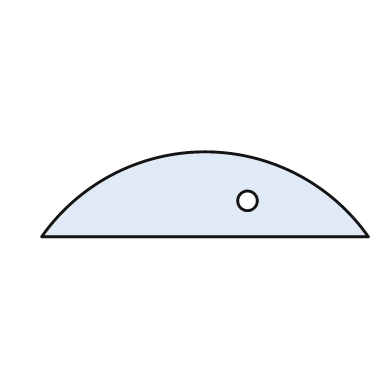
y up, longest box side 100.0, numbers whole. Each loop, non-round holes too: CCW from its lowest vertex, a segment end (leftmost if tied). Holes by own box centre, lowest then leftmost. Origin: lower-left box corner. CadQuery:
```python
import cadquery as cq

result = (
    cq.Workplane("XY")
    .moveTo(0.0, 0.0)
    .lineTo(100.0, 0.0)
    .threePointArc((50.0, 26.0), (0.0, 0.0))
    .close()
    .moveTo(63.0, 11.0)
    .circle(3.0)
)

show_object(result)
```